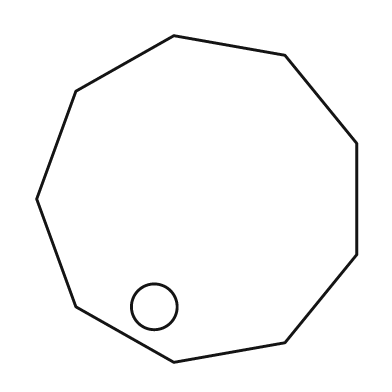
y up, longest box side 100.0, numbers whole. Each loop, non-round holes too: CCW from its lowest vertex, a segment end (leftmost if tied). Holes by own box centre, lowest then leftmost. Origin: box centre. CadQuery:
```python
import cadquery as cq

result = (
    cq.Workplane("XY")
    .moveTo(-7.0, -50.0)
    .lineTo(27.0, -44.0)
    .lineTo(49.0, -17.0)
    .lineTo(49.0, 17.0)
    .lineTo(27.0, 44.0)
    .lineTo(-7.0, 50.0)
    .lineTo(-37.0, 33.0)
    .lineTo(-49.0, 0.0)
    .lineTo(-37.0, -33.0)
    .close()
    .moveTo(-13.0, -33.0)
    .circle(7.0)
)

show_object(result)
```